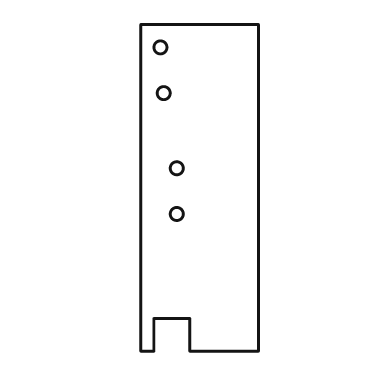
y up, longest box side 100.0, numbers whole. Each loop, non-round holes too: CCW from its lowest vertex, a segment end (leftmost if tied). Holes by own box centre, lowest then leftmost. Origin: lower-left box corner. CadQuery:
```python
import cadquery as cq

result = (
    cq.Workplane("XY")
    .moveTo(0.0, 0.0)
    .lineTo(4.0, 0.0)
    .lineTo(4.0, 10.0)
    .lineTo(15.0, 10.0)
    .lineTo(15.0, 0.0)
    .lineTo(36.0, 0.0)
    .lineTo(36.0, 100.0)
    .lineTo(0.0, 100.0)
    .close()
    .moveTo(11.0, 42.0)
    .circle(2.0)
    .moveTo(11.0, 56.0)
    .circle(2.0)
    .moveTo(7.0, 79.0)
    .circle(2.0)
    .moveTo(6.0, 93.0)
    .circle(2.0)
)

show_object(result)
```